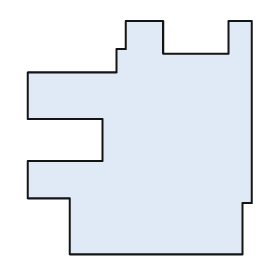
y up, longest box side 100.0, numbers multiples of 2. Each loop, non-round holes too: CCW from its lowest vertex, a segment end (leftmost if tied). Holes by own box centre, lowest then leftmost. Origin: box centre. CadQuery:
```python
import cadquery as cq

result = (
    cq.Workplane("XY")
    .moveTo(-30.0, -50.0)
    .lineTo(44.0, -50.0)
    .lineTo(44.0, -28.0)
    .lineTo(48.0, -28.0)
    .lineTo(48.0, 50.0)
    .lineTo(38.0, 50.0)
    .lineTo(38.0, 36.0)
    .lineTo(10.0, 36.0)
    .lineTo(10.0, 50.0)
    .lineTo(-6.0, 50.0)
    .lineTo(-6.0, 38.0)
    .lineTo(-10.0, 38.0)
    .lineTo(-10.0, 28.0)
    .lineTo(-48.0, 28.0)
    .lineTo(-48.0, 8.0)
    .lineTo(-16.0, 8.0)
    .lineTo(-16.0, -10.0)
    .lineTo(-48.0, -10.0)
    .lineTo(-48.0, -26.0)
    .lineTo(-30.0, -26.0)
    .close()
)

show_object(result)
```